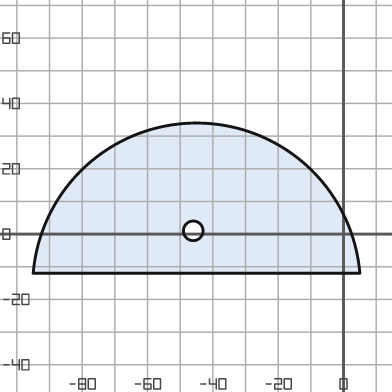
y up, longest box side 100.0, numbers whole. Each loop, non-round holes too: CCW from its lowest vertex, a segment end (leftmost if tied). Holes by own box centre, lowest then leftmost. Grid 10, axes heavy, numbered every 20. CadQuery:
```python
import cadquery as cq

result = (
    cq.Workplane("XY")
    .moveTo(-95.0, -12.0)
    .lineTo(5.0, -12.0)
    .threePointArc((-45.0, 34.0), (-95.0, -12.0))
    .close()
    .moveTo(-46.0, 1.0)
    .circle(3.0)
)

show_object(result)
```